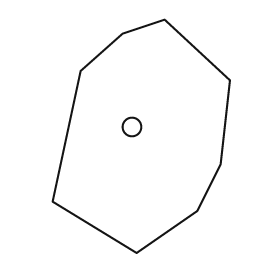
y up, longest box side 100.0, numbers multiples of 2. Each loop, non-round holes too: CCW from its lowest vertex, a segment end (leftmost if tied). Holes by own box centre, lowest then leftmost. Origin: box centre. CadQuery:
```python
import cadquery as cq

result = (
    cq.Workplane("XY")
    .moveTo(-2.0, -50.0)
    .lineTo(24.0, -32.0)
    .lineTo(34.0, -12.0)
    .lineTo(38.0, 24.0)
    .lineTo(10.0, 50.0)
    .lineTo(-8.0, 44.0)
    .lineTo(-26.0, 28.0)
    .lineTo(-38.0, -28.0)
    .close()
    .moveTo(-4.0, 4.0)
    .circle(4.0)
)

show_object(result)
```